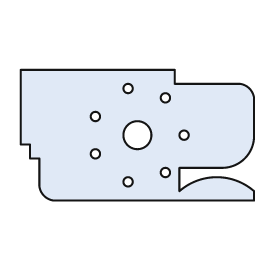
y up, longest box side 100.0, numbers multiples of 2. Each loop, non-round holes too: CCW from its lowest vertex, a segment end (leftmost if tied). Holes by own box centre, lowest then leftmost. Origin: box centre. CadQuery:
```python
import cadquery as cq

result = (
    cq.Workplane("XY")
    .moveTo(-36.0, -28.0)
    .lineTo(50.0, -28.0)
    .lineTo(50.0, -24.0)
    .threePointArc((34.0, -18.0), (18.0, -24.0))
    .lineTo(18.0, -14.0)
    .lineTo(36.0, -14.0)
    .threePointArc((46.0, -10.0), (50.0, 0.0))
    .lineTo(50.0, 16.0)
    .threePointArc((48.0, 20.0), (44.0, 22.0))
    .lineTo(16.0, 22.0)
    .lineTo(16.0, 28.0)
    .lineTo(-50.0, 28.0)
    .lineTo(-50.0, -4.0)
    .lineTo(-46.0, -4.0)
    .lineTo(-46.0, -10.0)
    .lineTo(-42.0, -10.0)
    .lineTo(-42.0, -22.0)
    .threePointArc((-40.0, -26.0), (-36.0, -28.0))
    .close()
    .moveTo(-4.0, -20.0)
    .circle(2.0)
    .moveTo(12.0, -16.0)
    .circle(2.0)
    .moveTo(-18.0, -8.0)
    .circle(2.0)
    .moveTo(0.0, 0.0)
    .circle(6.0)
    .moveTo(20.0, 0.0)
    .circle(2.0)
    .moveTo(-18.0, 8.0)
    .circle(2.0)
    .moveTo(12.0, 16.0)
    .circle(2.0)
    .moveTo(-4.0, 20.0)
    .circle(2.0)
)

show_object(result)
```